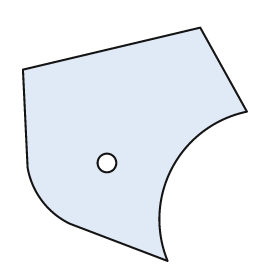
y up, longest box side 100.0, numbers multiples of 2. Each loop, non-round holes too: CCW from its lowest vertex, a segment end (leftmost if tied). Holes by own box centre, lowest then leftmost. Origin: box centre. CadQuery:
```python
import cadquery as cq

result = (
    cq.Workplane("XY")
    .moveTo(14.0, -50.0)
    .threePointArc((16.0, -10.0), (48.0, 14.0))
    .lineTo(28.0, 50.0)
    .lineTo(-48.0, 32.0)
    .lineTo(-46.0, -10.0)
    .threePointArc((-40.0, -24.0), (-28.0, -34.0))
    .close()
    .moveTo(-12.0, -8.0)
    .circle(4.0)
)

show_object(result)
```